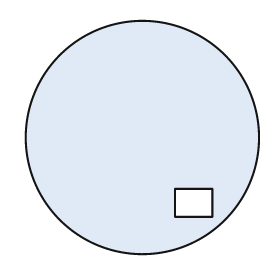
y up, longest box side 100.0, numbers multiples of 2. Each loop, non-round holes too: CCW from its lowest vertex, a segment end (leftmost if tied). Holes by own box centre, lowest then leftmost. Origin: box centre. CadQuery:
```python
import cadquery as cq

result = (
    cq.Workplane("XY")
    .moveTo(0.0, 0.0)
    .circle(50.0)
    .moveTo(14.0, -34.0)
    .lineTo(30.0, -34.0)
    .lineTo(30.0, -22.0)
    .lineTo(14.0, -22.0)
    .close()
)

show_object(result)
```